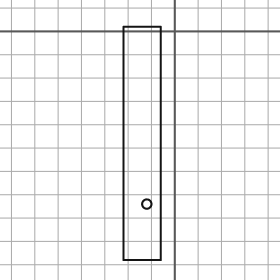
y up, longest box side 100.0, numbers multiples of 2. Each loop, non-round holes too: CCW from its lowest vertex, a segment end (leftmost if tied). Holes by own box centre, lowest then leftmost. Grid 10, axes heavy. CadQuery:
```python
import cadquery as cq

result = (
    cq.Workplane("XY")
    .moveTo(-22.0, -98.0)
    .lineTo(-6.0, -98.0)
    .lineTo(-6.0, 2.0)
    .lineTo(-22.0, 2.0)
    .close()
    .moveTo(-12.0, -74.0)
    .circle(2.0)
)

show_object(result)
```